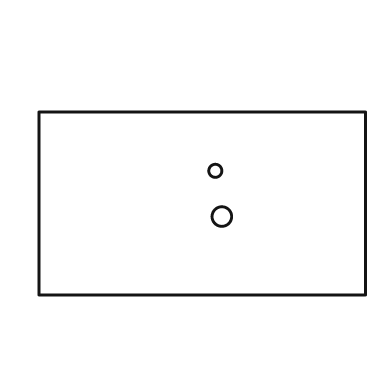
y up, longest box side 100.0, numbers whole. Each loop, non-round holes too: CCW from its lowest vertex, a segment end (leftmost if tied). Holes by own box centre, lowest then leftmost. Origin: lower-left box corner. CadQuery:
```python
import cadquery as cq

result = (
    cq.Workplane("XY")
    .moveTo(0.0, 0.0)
    .lineTo(100.0, 0.0)
    .lineTo(100.0, 56.0)
    .lineTo(0.0, 56.0)
    .close()
    .moveTo(56.0, 24.0)
    .circle(3.0)
    .moveTo(54.0, 38.0)
    .circle(2.0)
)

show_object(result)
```